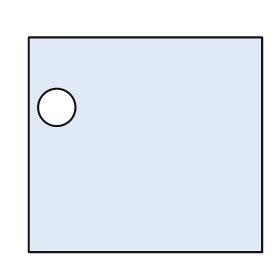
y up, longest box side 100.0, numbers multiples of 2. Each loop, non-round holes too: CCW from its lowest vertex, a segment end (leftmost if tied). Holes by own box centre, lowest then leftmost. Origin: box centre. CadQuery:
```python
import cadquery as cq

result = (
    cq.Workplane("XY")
    .moveTo(-50.0, -46.0)
    .lineTo(50.0, -46.0)
    .lineTo(50.0, 46.0)
    .lineTo(-50.0, 46.0)
    .close()
    .moveTo(-38.0, 16.0)
    .circle(8.0)
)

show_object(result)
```